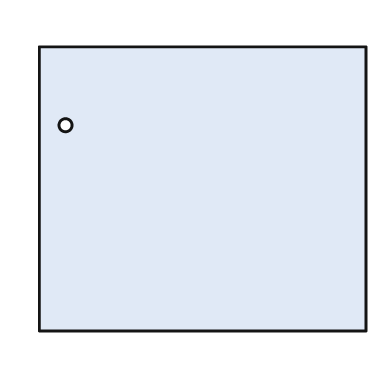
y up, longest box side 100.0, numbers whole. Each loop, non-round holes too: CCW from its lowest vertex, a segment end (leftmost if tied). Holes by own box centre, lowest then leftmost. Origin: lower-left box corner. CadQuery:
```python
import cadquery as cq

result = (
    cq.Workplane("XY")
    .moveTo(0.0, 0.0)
    .lineTo(100.0, 0.0)
    .lineTo(100.0, 87.0)
    .lineTo(0.0, 87.0)
    .close()
    .moveTo(8.0, 63.0)
    .circle(2.0)
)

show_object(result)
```